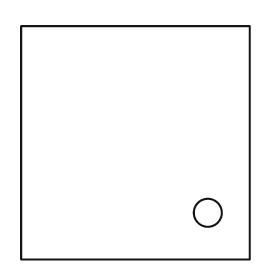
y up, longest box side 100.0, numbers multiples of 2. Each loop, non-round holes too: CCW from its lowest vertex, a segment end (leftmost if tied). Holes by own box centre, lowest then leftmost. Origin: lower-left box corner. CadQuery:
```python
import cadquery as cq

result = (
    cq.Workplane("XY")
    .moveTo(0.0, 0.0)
    .lineTo(98.0, 0.0)
    .lineTo(98.0, 100.0)
    .lineTo(0.0, 100.0)
    .close()
    .moveTo(80.0, 20.0)
    .circle(6.0)
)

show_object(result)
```